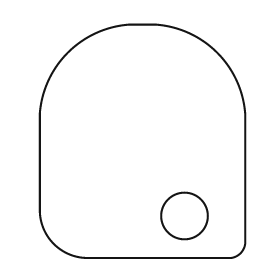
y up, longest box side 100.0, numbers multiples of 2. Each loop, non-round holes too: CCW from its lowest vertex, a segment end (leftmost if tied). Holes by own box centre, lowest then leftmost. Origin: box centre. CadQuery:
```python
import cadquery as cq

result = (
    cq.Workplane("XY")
    .moveTo(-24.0, -50.0)
    .lineTo(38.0, -50.0)
    .threePointArc((42.0, -48.0), (44.0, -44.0))
    .lineTo(44.0, 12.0)
    .threePointArc((32.0, 38.0), (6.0, 50.0))
    .lineTo(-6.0, 50.0)
    .threePointArc((-32.0, 38.0), (-44.0, 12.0))
    .lineTo(-44.0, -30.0)
    .threePointArc((-38.0, -44.0), (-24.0, -50.0))
    .close()
    .moveTo(18.0, -32.0)
    .circle(10.0)
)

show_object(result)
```